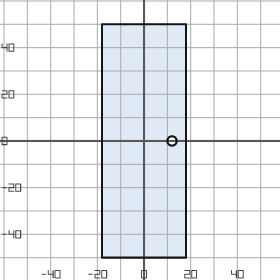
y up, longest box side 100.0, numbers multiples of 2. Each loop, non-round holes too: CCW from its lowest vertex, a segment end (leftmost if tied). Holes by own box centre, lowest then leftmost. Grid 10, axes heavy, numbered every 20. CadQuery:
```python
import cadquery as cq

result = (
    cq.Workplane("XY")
    .moveTo(-18.0, -50.0)
    .lineTo(18.0, -50.0)
    .lineTo(18.0, 50.0)
    .lineTo(-18.0, 50.0)
    .close()
    .moveTo(12.0, 0.0)
    .circle(2.0)
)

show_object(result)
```